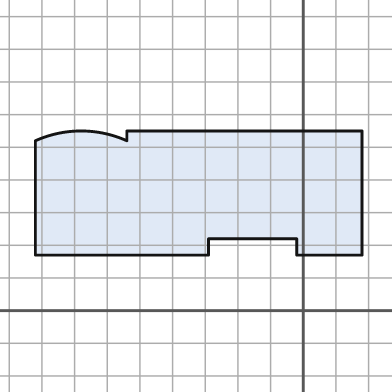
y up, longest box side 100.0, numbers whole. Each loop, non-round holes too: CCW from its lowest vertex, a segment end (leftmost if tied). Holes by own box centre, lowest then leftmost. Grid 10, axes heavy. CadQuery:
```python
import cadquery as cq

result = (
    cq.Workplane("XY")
    .moveTo(-82.0, 17.0)
    .lineTo(-29.0, 17.0)
    .lineTo(-29.0, 22.0)
    .lineTo(-2.0, 22.0)
    .lineTo(-2.0, 17.0)
    .lineTo(18.0, 17.0)
    .lineTo(18.0, 55.0)
    .lineTo(-54.0, 55.0)
    .lineTo(-54.0, 52.0)
    .threePointArc((-68.0, 55.0), (-82.0, 52.0))
    .close()
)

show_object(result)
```